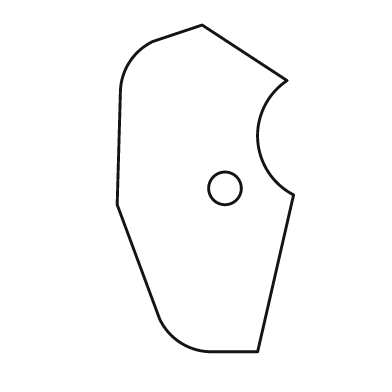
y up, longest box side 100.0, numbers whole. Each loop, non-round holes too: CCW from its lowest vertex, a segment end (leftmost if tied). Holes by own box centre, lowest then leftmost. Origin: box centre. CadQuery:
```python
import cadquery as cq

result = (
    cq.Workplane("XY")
    .moveTo(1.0, -50.0)
    .lineTo(16.0, -50.0)
    .lineTo(27.0, -2.0)
    .threePointArc((16.0, 15.0), (25.0, 33.0))
    .lineTo(-1.0, 50.0)
    .lineTo(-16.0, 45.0)
    .threePointArc((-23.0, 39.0), (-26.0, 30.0))
    .lineTo(-27.0, -5.0)
    .lineTo(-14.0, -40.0)
    .threePointArc((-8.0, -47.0), (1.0, -50.0))
    .close()
    .moveTo(6.0, 0.0)
    .circle(5.0)
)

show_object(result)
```